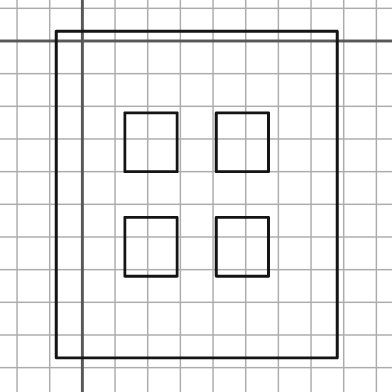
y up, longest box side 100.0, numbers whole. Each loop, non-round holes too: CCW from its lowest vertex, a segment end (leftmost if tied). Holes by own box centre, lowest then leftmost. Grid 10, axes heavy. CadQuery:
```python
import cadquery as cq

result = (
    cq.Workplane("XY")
    .moveTo(-8.0, -97.0)
    .lineTo(78.0, -97.0)
    .lineTo(78.0, 3.0)
    .lineTo(-8.0, 3.0)
    .close()
    .moveTo(13.0, -72.0)
    .lineTo(29.0, -72.0)
    .lineTo(29.0, -54.0)
    .lineTo(13.0, -54.0)
    .close()
    .moveTo(41.0, -72.0)
    .lineTo(57.0, -72.0)
    .lineTo(57.0, -54.0)
    .lineTo(41.0, -54.0)
    .close()
    .moveTo(13.0, -40.0)
    .lineTo(29.0, -40.0)
    .lineTo(29.0, -22.0)
    .lineTo(13.0, -22.0)
    .close()
    .moveTo(41.0, -40.0)
    .lineTo(57.0, -40.0)
    .lineTo(57.0, -22.0)
    .lineTo(41.0, -22.0)
    .close()
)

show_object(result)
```